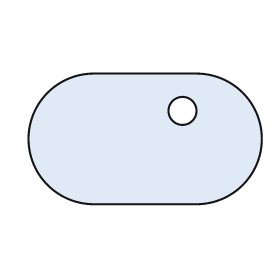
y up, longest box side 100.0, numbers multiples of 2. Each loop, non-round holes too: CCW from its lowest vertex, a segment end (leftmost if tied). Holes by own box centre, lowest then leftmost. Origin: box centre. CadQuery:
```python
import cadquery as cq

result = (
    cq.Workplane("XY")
    .moveTo(-22.0, -28.0)
    .lineTo(22.0, -28.0)
    .threePointArc((50.0, 0.0), (22.0, 28.0))
    .lineTo(-22.0, 28.0)
    .threePointArc((-50.0, 0.0), (-22.0, -28.0))
    .close()
    .moveTo(16.0, 12.0)
    .circle(6.0)
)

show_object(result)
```